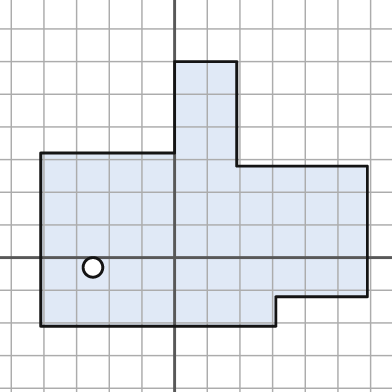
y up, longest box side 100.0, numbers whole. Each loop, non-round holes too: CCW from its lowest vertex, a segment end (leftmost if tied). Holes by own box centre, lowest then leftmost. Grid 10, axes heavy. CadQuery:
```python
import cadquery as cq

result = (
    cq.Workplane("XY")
    .moveTo(-41.0, -21.0)
    .lineTo(31.0, -21.0)
    .lineTo(31.0, -12.0)
    .lineTo(59.0, -12.0)
    .lineTo(59.0, 28.0)
    .lineTo(19.0, 28.0)
    .lineTo(19.0, 60.0)
    .lineTo(0.0, 60.0)
    .lineTo(0.0, 32.0)
    .lineTo(-41.0, 32.0)
    .close()
    .moveTo(-25.0, -3.0)
    .circle(3.0)
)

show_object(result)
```